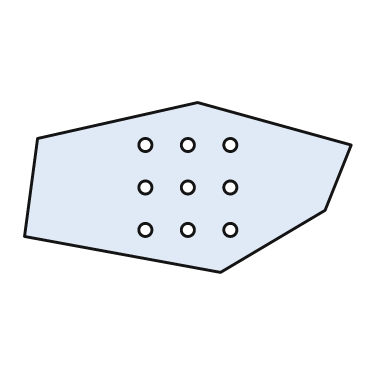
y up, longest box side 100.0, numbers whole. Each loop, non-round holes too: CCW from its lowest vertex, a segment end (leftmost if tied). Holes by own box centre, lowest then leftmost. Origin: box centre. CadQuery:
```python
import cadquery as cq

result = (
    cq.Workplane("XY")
    .moveTo(10.0, -26.0)
    .lineTo(42.0, -7.0)
    .lineTo(50.0, 13.0)
    .lineTo(3.0, 26.0)
    .lineTo(-46.0, 15.0)
    .lineTo(-50.0, -15.0)
    .close()
    .moveTo(-13.0, -13.0)
    .circle(2.0)
    .moveTo(0.0, -13.0)
    .circle(2.0)
    .moveTo(13.0, -13.0)
    .circle(2.0)
    .moveTo(-13.0, 0.0)
    .circle(2.0)
    .moveTo(0.0, 0.0)
    .circle(2.0)
    .moveTo(13.0, 0.0)
    .circle(2.0)
    .moveTo(-13.0, 13.0)
    .circle(2.0)
    .moveTo(0.0, 13.0)
    .circle(2.0)
    .moveTo(13.0, 13.0)
    .circle(2.0)
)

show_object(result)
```